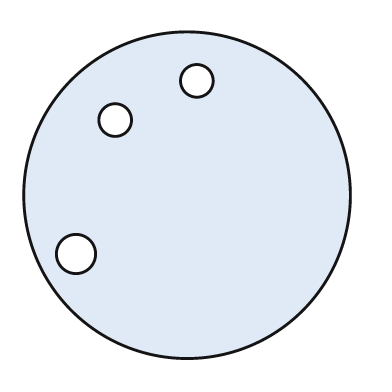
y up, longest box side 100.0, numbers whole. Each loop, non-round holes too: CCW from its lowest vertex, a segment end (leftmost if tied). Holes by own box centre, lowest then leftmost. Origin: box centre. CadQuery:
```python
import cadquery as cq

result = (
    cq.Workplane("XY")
    .moveTo(0.0, 0.0)
    .circle(50.0)
    .moveTo(-34.0, -18.0)
    .circle(6.0)
    .moveTo(-22.0, 23.0)
    .circle(5.0)
    .moveTo(3.0, 35.0)
    .circle(5.0)
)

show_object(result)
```